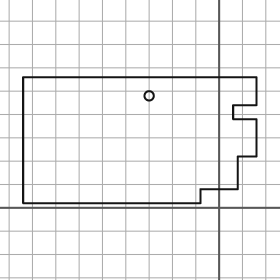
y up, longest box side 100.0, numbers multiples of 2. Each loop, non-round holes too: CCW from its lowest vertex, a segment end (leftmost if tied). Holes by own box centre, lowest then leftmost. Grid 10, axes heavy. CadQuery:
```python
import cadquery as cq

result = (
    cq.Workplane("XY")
    .moveTo(-84.0, 2.0)
    .lineTo(-8.0, 2.0)
    .lineTo(-8.0, 8.0)
    .lineTo(8.0, 8.0)
    .lineTo(8.0, 22.0)
    .lineTo(16.0, 22.0)
    .lineTo(16.0, 38.0)
    .lineTo(6.0, 38.0)
    .lineTo(6.0, 44.0)
    .lineTo(16.0, 44.0)
    .lineTo(16.0, 56.0)
    .lineTo(-84.0, 56.0)
    .close()
    .moveTo(-30.0, 48.0)
    .circle(2.0)
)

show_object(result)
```